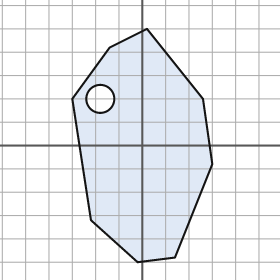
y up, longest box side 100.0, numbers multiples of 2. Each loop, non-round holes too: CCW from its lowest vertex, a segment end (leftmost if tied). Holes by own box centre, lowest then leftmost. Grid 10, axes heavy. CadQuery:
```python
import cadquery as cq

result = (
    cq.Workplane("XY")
    .moveTo(-2.0, -50.0)
    .lineTo(14.0, -48.0)
    .lineTo(30.0, -8.0)
    .lineTo(26.0, 20.0)
    .lineTo(2.0, 50.0)
    .lineTo(-14.0, 42.0)
    .lineTo(-30.0, 20.0)
    .lineTo(-22.0, -32.0)
    .close()
    .moveTo(-18.0, 20.0)
    .circle(6.0)
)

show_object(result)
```